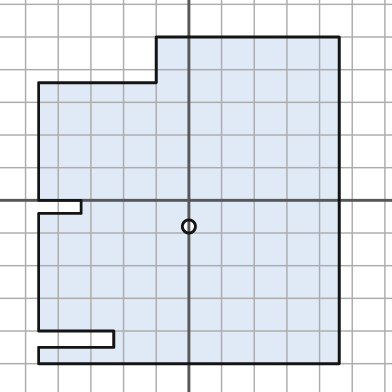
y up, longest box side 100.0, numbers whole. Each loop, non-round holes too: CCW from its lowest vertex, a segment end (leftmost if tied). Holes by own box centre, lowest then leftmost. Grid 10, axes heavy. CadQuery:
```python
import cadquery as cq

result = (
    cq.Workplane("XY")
    .moveTo(-46.0, -50.0)
    .lineTo(46.0, -50.0)
    .lineTo(46.0, 50.0)
    .lineTo(-10.0, 50.0)
    .lineTo(-10.0, 36.0)
    .lineTo(-46.0, 36.0)
    .lineTo(-46.0, 0.0)
    .lineTo(-33.0, 0.0)
    .lineTo(-33.0, -4.0)
    .lineTo(-46.0, -4.0)
    .lineTo(-46.0, -40.0)
    .lineTo(-23.0, -40.0)
    .lineTo(-23.0, -45.0)
    .lineTo(-46.0, -45.0)
    .close()
    .moveTo(0.0, -8.0)
    .circle(2.0)
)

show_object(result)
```